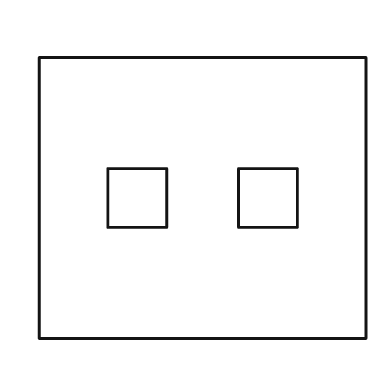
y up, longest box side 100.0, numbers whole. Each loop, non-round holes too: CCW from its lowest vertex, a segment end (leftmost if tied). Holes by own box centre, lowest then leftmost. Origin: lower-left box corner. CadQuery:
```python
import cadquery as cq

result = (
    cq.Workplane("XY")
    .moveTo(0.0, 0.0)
    .lineTo(100.0, 0.0)
    .lineTo(100.0, 86.0)
    .lineTo(0.0, 86.0)
    .close()
    .moveTo(21.0, 34.0)
    .lineTo(39.0, 34.0)
    .lineTo(39.0, 52.0)
    .lineTo(21.0, 52.0)
    .close()
    .moveTo(61.0, 34.0)
    .lineTo(79.0, 34.0)
    .lineTo(79.0, 52.0)
    .lineTo(61.0, 52.0)
    .close()
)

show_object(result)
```